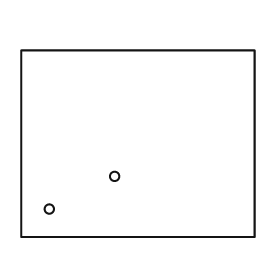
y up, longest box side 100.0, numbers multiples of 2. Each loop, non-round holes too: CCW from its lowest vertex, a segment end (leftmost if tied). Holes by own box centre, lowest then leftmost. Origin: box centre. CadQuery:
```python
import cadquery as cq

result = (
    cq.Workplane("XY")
    .moveTo(-50.0, -40.0)
    .lineTo(50.0, -40.0)
    .lineTo(50.0, 40.0)
    .lineTo(-50.0, 40.0)
    .close()
    .moveTo(-38.0, -28.0)
    .circle(2.0)
    .moveTo(-10.0, -14.0)
    .circle(2.0)
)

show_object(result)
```